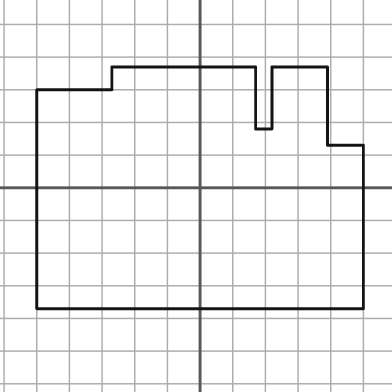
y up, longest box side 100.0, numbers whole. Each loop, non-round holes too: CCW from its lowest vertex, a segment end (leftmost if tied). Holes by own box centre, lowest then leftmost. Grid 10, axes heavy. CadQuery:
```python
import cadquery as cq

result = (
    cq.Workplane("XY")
    .moveTo(-50.0, -37.0)
    .lineTo(50.0, -37.0)
    .lineTo(50.0, 13.0)
    .lineTo(39.0, 13.0)
    .lineTo(39.0, 37.0)
    .lineTo(22.0, 37.0)
    .lineTo(22.0, 18.0)
    .lineTo(17.0, 18.0)
    .lineTo(17.0, 37.0)
    .lineTo(-27.0, 37.0)
    .lineTo(-27.0, 30.0)
    .lineTo(-50.0, 30.0)
    .close()
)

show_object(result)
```